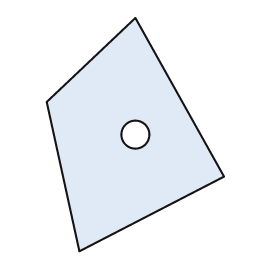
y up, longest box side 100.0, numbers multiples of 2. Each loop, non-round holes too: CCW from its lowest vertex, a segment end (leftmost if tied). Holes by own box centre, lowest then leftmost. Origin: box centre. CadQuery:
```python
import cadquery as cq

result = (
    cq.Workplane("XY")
    .moveTo(-24.0, -50.0)
    .lineTo(38.0, -18.0)
    .lineTo(0.0, 50.0)
    .lineTo(-38.0, 14.0)
    .close()
    .moveTo(0.0, 0.0)
    .circle(6.0)
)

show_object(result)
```